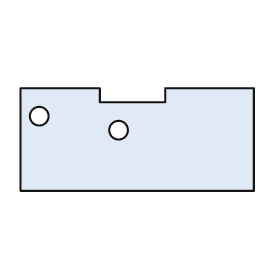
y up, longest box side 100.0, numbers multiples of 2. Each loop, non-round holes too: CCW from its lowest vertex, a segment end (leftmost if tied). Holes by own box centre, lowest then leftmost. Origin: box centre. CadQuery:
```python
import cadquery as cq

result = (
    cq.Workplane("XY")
    .moveTo(-50.0, -22.0)
    .lineTo(50.0, -22.0)
    .lineTo(50.0, 22.0)
    .lineTo(12.0, 22.0)
    .lineTo(12.0, 16.0)
    .lineTo(-16.0, 16.0)
    .lineTo(-16.0, 22.0)
    .lineTo(-50.0, 22.0)
    .close()
    .moveTo(-8.0, 4.0)
    .circle(4.0)
    .moveTo(-42.0, 10.0)
    .circle(4.0)
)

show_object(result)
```